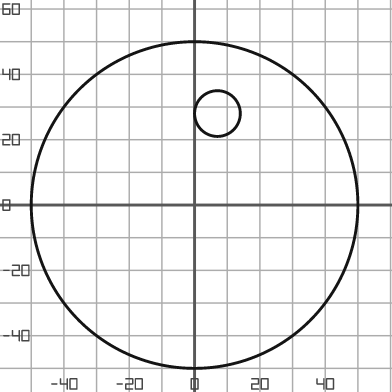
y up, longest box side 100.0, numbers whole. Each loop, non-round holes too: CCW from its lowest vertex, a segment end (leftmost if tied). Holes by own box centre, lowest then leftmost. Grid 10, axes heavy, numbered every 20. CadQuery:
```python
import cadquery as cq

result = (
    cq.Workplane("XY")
    .moveTo(0.0, 0.0)
    .circle(50.0)
    .moveTo(7.0, 28.0)
    .circle(7.0)
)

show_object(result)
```